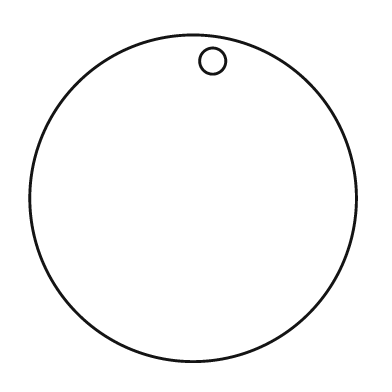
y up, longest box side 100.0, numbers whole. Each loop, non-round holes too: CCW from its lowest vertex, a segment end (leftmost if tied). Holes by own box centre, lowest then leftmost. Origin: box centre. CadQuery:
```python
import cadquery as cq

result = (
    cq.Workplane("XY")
    .moveTo(0.0, 0.0)
    .circle(50.0)
    .moveTo(6.0, 42.0)
    .circle(4.0)
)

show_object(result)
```